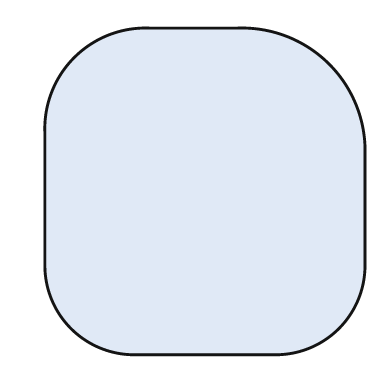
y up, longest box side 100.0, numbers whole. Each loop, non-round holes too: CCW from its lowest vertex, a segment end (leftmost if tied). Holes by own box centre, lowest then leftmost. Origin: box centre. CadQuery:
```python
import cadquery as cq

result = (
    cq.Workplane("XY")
    .moveTo(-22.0, -50.0)
    .lineTo(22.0, -50.0)
    .threePointArc((41.0, -42.0), (49.0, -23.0))
    .lineTo(49.0, 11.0)
    .threePointArc((38.0, 39.0), (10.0, 50.0))
    .lineTo(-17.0, 50.0)
    .threePointArc((-40.0, 41.0), (-49.0, 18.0))
    .lineTo(-49.0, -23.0)
    .threePointArc((-41.0, -42.0), (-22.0, -50.0))
    .close()
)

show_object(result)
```